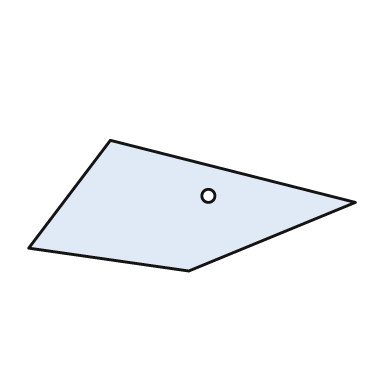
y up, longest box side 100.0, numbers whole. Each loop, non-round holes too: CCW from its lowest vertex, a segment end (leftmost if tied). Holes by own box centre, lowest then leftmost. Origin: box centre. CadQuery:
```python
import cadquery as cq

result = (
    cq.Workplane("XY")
    .moveTo(-1.0, -20.0)
    .lineTo(50.0, 1.0)
    .lineTo(-25.0, 20.0)
    .lineTo(-50.0, -13.0)
    .close()
    .moveTo(5.0, 3.0)
    .circle(2.0)
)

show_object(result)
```